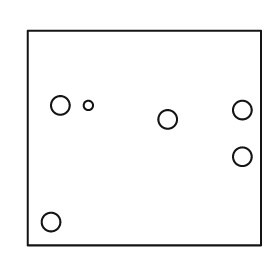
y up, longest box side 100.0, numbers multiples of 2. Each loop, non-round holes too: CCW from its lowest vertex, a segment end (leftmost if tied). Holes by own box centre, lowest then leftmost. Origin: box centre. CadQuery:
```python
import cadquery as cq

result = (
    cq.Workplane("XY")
    .moveTo(-50.0, -46.0)
    .lineTo(50.0, -46.0)
    .lineTo(50.0, 46.0)
    .lineTo(-50.0, 46.0)
    .close()
    .moveTo(-40.0, -36.0)
    .circle(4.0)
    .moveTo(42.0, -8.0)
    .circle(4.0)
    .moveTo(10.0, 8.0)
    .circle(4.0)
    .moveTo(42.0, 12.0)
    .circle(4.0)
    .moveTo(-36.0, 14.0)
    .circle(4.0)
    .moveTo(-24.0, 14.0)
    .circle(2.0)
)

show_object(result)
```